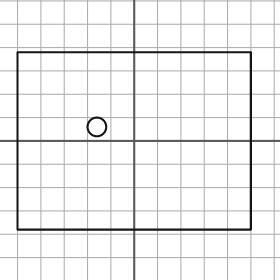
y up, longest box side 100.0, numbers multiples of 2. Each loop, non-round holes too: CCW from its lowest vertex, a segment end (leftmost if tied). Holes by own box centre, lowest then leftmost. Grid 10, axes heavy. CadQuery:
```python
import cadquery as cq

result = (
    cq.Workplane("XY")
    .moveTo(-50.0, -38.0)
    .lineTo(50.0, -38.0)
    .lineTo(50.0, 38.0)
    .lineTo(-50.0, 38.0)
    .close()
    .moveTo(-16.0, 6.0)
    .circle(4.0)
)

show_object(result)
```